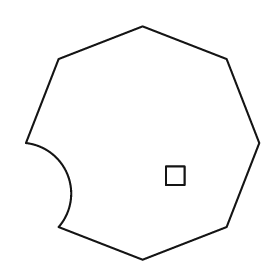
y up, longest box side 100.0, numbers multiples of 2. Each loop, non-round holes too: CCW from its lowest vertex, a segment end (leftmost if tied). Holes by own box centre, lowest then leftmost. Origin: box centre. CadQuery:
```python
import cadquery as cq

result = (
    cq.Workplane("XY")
    .moveTo(0.0, -50.0)
    .lineTo(36.0, -36.0)
    .lineTo(50.0, 0.0)
    .lineTo(36.0, 36.0)
    .lineTo(0.0, 50.0)
    .lineTo(-36.0, 36.0)
    .lineTo(-50.0, 0.0)
    .threePointArc((-32.0, -14.0), (-36.0, -36.0))
    .close()
    .moveTo(10.0, -18.0)
    .lineTo(18.0, -18.0)
    .lineTo(18.0, -10.0)
    .lineTo(10.0, -10.0)
    .close()
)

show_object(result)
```